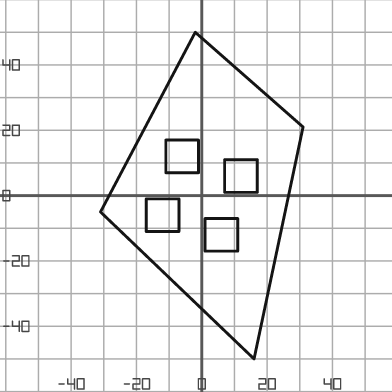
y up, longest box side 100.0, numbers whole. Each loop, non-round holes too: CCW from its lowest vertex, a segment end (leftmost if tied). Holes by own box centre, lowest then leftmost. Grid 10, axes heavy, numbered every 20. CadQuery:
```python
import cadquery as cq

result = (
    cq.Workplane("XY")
    .moveTo(16.0, -50.0)
    .lineTo(31.0, 21.0)
    .lineTo(-2.0, 50.0)
    .lineTo(-31.0, -5.0)
    .close()
    .moveTo(1.0, -17.0)
    .lineTo(11.0, -17.0)
    .lineTo(11.0, -7.0)
    .lineTo(1.0, -7.0)
    .close()
    .moveTo(-17.0, -11.0)
    .lineTo(-7.0, -11.0)
    .lineTo(-7.0, -1.0)
    .lineTo(-17.0, -1.0)
    .close()
    .moveTo(7.0, 1.0)
    .lineTo(17.0, 1.0)
    .lineTo(17.0, 11.0)
    .lineTo(7.0, 11.0)
    .close()
    .moveTo(-11.0, 7.0)
    .lineTo(-1.0, 7.0)
    .lineTo(-1.0, 17.0)
    .lineTo(-11.0, 17.0)
    .close()
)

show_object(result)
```